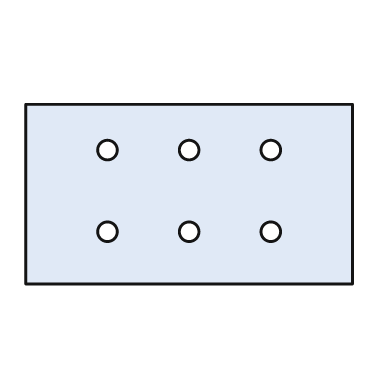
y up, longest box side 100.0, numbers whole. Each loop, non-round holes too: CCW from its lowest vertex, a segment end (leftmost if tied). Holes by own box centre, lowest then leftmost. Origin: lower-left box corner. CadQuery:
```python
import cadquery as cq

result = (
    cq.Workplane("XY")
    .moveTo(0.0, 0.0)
    .lineTo(100.0, 0.0)
    .lineTo(100.0, 55.0)
    .lineTo(0.0, 55.0)
    .close()
    .moveTo(25.0, 16.0)
    .circle(3.0)
    .moveTo(50.0, 16.0)
    .circle(3.0)
    .moveTo(75.0, 16.0)
    .circle(3.0)
    .moveTo(25.0, 41.0)
    .circle(3.0)
    .moveTo(50.0, 41.0)
    .circle(3.0)
    .moveTo(75.0, 41.0)
    .circle(3.0)
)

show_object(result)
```